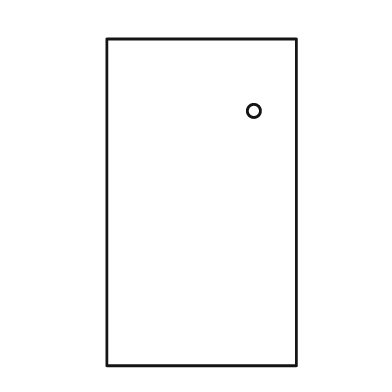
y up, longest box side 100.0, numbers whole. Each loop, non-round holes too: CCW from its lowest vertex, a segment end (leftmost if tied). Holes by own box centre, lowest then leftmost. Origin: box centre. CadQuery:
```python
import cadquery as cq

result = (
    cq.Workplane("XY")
    .moveTo(-29.0, -50.0)
    .lineTo(29.0, -50.0)
    .lineTo(29.0, 50.0)
    .lineTo(-29.0, 50.0)
    .close()
    .moveTo(16.0, 28.0)
    .circle(2.0)
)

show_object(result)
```